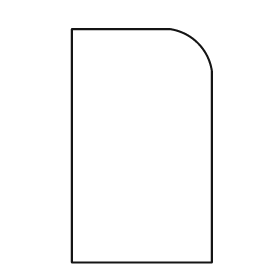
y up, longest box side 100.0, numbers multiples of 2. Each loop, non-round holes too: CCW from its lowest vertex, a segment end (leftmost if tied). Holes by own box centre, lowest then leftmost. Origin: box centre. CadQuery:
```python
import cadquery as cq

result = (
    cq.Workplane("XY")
    .moveTo(-30.0, -50.0)
    .lineTo(30.0, -50.0)
    .lineTo(30.0, 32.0)
    .threePointArc((24.0, 44.0), (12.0, 50.0))
    .lineTo(-30.0, 50.0)
    .close()
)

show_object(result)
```